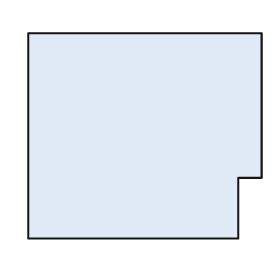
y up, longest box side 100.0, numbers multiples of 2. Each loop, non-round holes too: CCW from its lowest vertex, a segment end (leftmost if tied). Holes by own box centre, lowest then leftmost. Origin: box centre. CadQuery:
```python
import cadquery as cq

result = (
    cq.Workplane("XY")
    .moveTo(-50.0, -44.0)
    .lineTo(40.0, -44.0)
    .lineTo(40.0, -18.0)
    .lineTo(50.0, -18.0)
    .lineTo(50.0, 44.0)
    .lineTo(-50.0, 44.0)
    .close()
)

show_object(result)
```